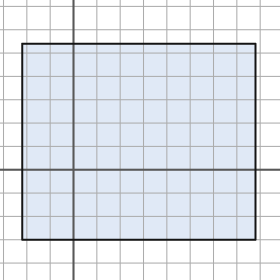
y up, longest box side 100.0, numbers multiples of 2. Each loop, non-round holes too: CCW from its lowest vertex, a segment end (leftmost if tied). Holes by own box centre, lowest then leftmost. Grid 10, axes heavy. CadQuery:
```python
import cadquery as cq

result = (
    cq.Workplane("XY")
    .moveTo(-22.0, -30.0)
    .lineTo(78.0, -30.0)
    .lineTo(78.0, 54.0)
    .lineTo(-22.0, 54.0)
    .close()
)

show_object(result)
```